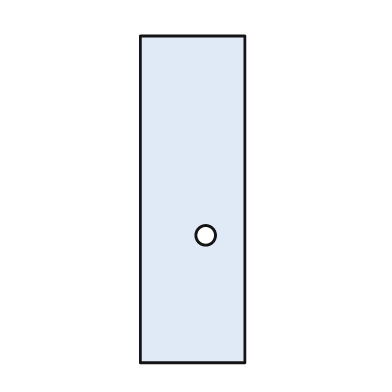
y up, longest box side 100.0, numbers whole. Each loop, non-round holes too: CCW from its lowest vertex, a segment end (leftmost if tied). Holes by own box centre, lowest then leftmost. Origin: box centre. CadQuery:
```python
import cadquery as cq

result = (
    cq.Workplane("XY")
    .moveTo(-16.0, -50.0)
    .lineTo(16.0, -50.0)
    .lineTo(16.0, 50.0)
    .lineTo(-16.0, 50.0)
    .close()
    .moveTo(4.0, -11.0)
    .circle(3.0)
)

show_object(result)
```